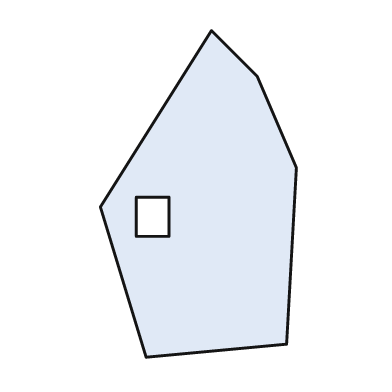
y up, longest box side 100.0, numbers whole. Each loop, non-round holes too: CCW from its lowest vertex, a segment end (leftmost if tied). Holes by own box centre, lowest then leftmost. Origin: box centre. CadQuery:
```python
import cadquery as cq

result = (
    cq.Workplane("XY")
    .moveTo(-16.0, -50.0)
    .lineTo(27.0, -46.0)
    .lineTo(30.0, 8.0)
    .lineTo(18.0, 36.0)
    .lineTo(4.0, 50.0)
    .lineTo(-30.0, -4.0)
    .close()
    .moveTo(-19.0, -13.0)
    .lineTo(-9.0, -13.0)
    .lineTo(-9.0, -1.0)
    .lineTo(-19.0, -1.0)
    .close()
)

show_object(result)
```